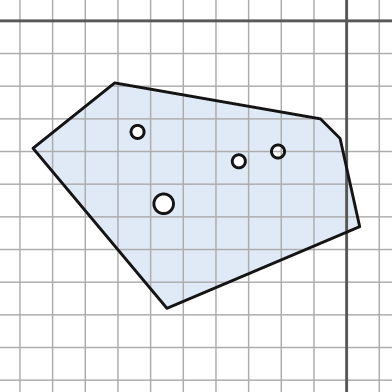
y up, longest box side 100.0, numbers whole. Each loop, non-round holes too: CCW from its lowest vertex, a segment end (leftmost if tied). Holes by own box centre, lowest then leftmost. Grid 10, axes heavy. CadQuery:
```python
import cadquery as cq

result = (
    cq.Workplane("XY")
    .moveTo(-55.0, -88.0)
    .lineTo(4.0, -63.0)
    .lineTo(-2.0, -36.0)
    .lineTo(-8.0, -30.0)
    .lineTo(-71.0, -19.0)
    .lineTo(-96.0, -39.0)
    .close()
    .moveTo(-56.0, -56.0)
    .circle(3.0)
    .moveTo(-33.0, -43.0)
    .circle(2.0)
    .moveTo(-21.0, -40.0)
    .circle(2.0)
    .moveTo(-64.0, -34.0)
    .circle(2.0)
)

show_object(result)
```